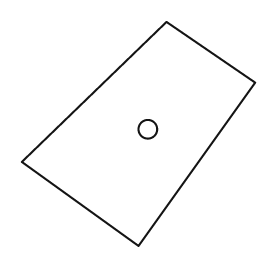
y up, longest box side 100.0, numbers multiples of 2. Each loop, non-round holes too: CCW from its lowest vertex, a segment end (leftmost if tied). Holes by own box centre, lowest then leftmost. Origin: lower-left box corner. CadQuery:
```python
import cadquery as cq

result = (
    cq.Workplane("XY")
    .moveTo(50.0, 0.0)
    .lineTo(100.0, 70.0)
    .lineTo(62.0, 96.0)
    .lineTo(0.0, 36.0)
    .close()
    .moveTo(54.0, 50.0)
    .circle(4.0)
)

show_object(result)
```